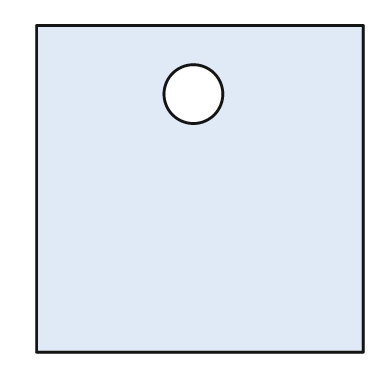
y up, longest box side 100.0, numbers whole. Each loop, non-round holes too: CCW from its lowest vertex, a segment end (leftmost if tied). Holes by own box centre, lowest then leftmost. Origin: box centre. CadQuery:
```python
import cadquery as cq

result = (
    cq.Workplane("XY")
    .moveTo(-50.0, -50.0)
    .lineTo(50.0, -50.0)
    .lineTo(50.0, 50.0)
    .lineTo(-50.0, 50.0)
    .close()
    .moveTo(-2.0, 29.0)
    .circle(9.0)
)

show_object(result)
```